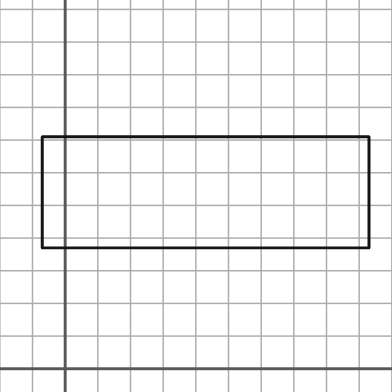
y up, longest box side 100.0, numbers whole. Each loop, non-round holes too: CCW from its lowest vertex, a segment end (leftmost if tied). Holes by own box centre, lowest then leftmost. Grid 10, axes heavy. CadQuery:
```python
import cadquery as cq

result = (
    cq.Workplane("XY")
    .moveTo(-7.0, 37.0)
    .lineTo(93.0, 37.0)
    .lineTo(93.0, 71.0)
    .lineTo(-7.0, 71.0)
    .close()
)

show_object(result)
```